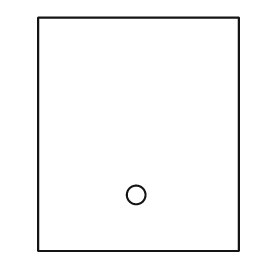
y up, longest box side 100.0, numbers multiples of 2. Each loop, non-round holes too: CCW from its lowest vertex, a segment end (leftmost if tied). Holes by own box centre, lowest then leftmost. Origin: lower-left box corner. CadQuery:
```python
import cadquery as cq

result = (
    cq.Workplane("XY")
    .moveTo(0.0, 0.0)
    .lineTo(86.0, 0.0)
    .lineTo(86.0, 100.0)
    .lineTo(0.0, 100.0)
    .close()
    .moveTo(42.0, 24.0)
    .circle(4.0)
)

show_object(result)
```